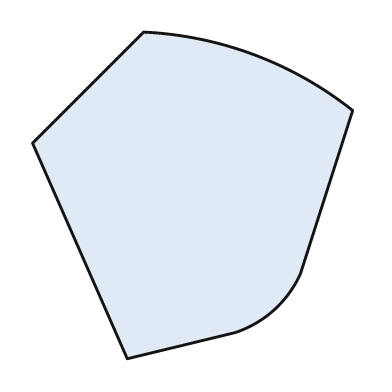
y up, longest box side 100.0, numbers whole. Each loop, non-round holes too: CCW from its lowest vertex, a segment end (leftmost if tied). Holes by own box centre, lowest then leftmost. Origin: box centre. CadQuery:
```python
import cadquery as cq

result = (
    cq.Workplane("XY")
    .moveTo(-20.0, -50.0)
    .lineTo(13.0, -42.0)
    .threePointArc((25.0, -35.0), (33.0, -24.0))
    .lineTo(49.0, 26.0)
    .threePointArc((19.0, 43.0), (-15.0, 50.0))
    .lineTo(-49.0, 16.0)
    .close()
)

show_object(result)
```